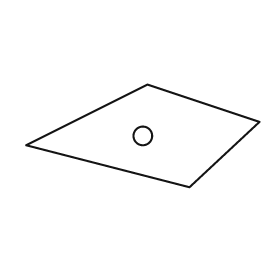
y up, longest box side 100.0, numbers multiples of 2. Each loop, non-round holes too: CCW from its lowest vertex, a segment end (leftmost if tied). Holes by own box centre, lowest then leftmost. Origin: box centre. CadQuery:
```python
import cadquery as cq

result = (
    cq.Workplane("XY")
    .moveTo(20.0, -22.0)
    .lineTo(50.0, 6.0)
    .lineTo(2.0, 22.0)
    .lineTo(-50.0, -4.0)
    .close()
    .moveTo(0.0, 0.0)
    .circle(4.0)
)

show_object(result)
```